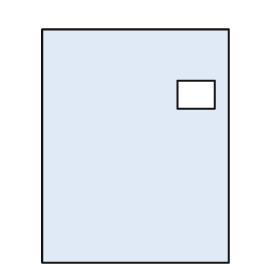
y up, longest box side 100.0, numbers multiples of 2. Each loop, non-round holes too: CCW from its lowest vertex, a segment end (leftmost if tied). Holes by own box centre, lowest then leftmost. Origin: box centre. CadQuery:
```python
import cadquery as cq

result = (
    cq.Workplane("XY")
    .moveTo(-40.0, -50.0)
    .lineTo(40.0, -50.0)
    .lineTo(40.0, 50.0)
    .lineTo(-40.0, 50.0)
    .close()
    .moveTo(18.0, 16.0)
    .lineTo(34.0, 16.0)
    .lineTo(34.0, 28.0)
    .lineTo(18.0, 28.0)
    .close()
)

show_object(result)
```